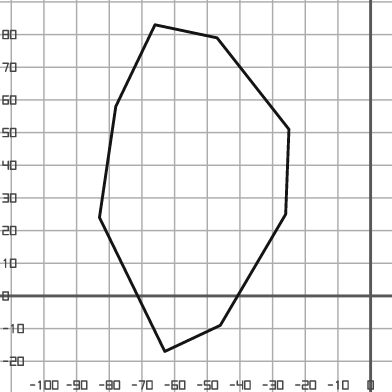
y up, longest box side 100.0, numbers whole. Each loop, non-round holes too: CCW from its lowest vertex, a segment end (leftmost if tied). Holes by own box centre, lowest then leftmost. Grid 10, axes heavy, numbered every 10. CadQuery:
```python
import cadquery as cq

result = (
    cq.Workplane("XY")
    .moveTo(-63.0, -17.0)
    .lineTo(-46.0, -9.0)
    .lineTo(-26.0, 25.0)
    .lineTo(-25.0, 51.0)
    .lineTo(-47.0, 79.0)
    .lineTo(-66.0, 83.0)
    .lineTo(-78.0, 58.0)
    .lineTo(-83.0, 24.0)
    .close()
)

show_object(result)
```